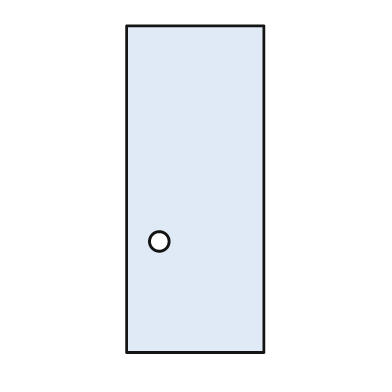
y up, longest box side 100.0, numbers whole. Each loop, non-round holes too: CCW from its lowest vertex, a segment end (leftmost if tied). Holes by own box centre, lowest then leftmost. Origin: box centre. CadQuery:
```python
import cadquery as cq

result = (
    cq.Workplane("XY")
    .moveTo(-21.0, -50.0)
    .lineTo(21.0, -50.0)
    .lineTo(21.0, 50.0)
    .lineTo(-21.0, 50.0)
    .close()
    .moveTo(-11.0, -16.0)
    .circle(3.0)
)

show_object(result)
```